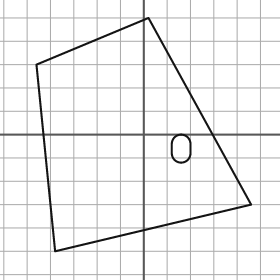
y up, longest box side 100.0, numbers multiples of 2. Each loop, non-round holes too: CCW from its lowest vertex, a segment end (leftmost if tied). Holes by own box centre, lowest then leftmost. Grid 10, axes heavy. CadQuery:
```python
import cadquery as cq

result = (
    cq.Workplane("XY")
    .moveTo(-38.0, -50.0)
    .lineTo(46.0, -30.0)
    .lineTo(2.0, 50.0)
    .lineTo(-46.0, 30.0)
    .close()
    .moveTo(12.0, -8.0)
    .threePointArc((16.0, -12.0), (20.0, -8.0))
    .lineTo(20.0, -4.0)
    .threePointArc((16.0, 0.0), (12.0, -4.0))
    .close()
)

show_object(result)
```